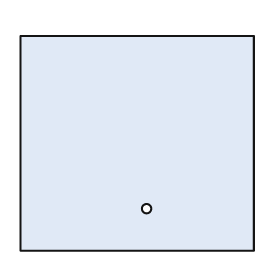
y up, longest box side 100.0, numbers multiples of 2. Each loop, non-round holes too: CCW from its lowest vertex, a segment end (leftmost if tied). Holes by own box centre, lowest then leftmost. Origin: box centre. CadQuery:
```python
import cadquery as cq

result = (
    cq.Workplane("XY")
    .moveTo(-50.0, -46.0)
    .lineTo(50.0, -46.0)
    .lineTo(50.0, 46.0)
    .lineTo(-50.0, 46.0)
    .close()
    .moveTo(4.0, -28.0)
    .circle(2.0)
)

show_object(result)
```